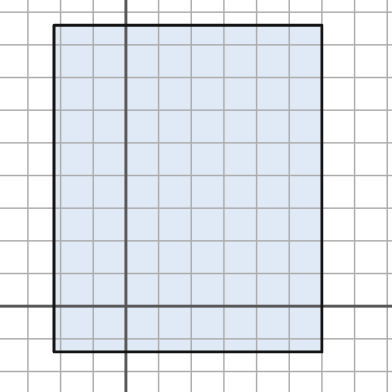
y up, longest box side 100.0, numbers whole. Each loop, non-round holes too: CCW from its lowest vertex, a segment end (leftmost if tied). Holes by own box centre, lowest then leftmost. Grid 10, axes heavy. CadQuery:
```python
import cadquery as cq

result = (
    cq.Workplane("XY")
    .moveTo(-22.0, -14.0)
    .lineTo(60.0, -14.0)
    .lineTo(60.0, 86.0)
    .lineTo(-22.0, 86.0)
    .close()
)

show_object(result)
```